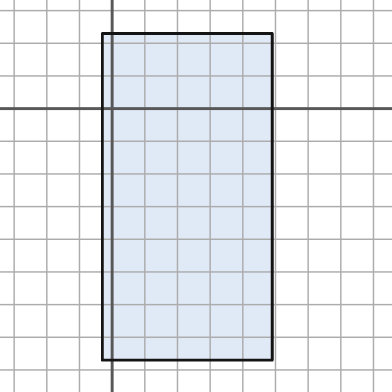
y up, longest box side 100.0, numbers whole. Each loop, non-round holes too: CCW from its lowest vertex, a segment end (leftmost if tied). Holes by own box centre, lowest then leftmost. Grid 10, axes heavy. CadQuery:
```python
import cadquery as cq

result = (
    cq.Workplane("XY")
    .moveTo(-3.0, -77.0)
    .lineTo(49.0, -77.0)
    .lineTo(49.0, 23.0)
    .lineTo(-3.0, 23.0)
    .close()
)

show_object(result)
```